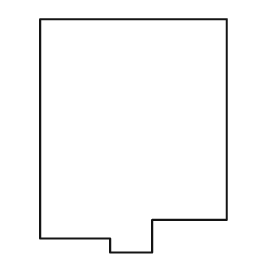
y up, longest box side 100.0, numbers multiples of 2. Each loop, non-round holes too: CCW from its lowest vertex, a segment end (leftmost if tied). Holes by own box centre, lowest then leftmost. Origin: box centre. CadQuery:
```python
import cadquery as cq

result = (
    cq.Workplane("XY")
    .moveTo(-10.0, -50.0)
    .lineTo(8.0, -50.0)
    .lineTo(8.0, -36.0)
    .lineTo(40.0, -36.0)
    .lineTo(40.0, 50.0)
    .lineTo(-40.0, 50.0)
    .lineTo(-40.0, -44.0)
    .lineTo(-10.0, -44.0)
    .close()
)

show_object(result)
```